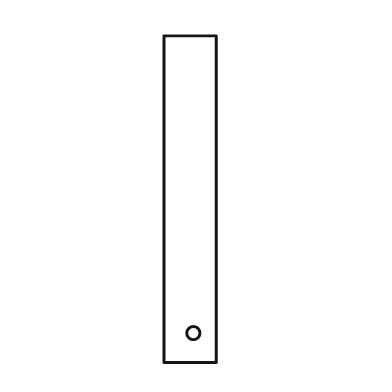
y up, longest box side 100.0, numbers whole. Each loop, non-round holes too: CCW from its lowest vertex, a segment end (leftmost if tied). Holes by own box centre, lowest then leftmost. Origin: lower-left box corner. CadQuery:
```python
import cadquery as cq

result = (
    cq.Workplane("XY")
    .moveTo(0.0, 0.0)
    .lineTo(16.0, 0.0)
    .lineTo(16.0, 100.0)
    .lineTo(0.0, 100.0)
    .close()
    .moveTo(9.0, 9.0)
    .circle(2.0)
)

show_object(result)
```